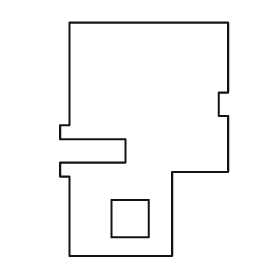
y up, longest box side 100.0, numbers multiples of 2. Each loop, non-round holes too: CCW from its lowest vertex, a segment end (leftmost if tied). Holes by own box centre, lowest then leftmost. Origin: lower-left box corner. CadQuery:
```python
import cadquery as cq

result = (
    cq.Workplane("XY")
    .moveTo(4.0, 0.0)
    .lineTo(48.0, 0.0)
    .lineTo(48.0, 36.0)
    .lineTo(72.0, 36.0)
    .lineTo(72.0, 60.0)
    .lineTo(68.0, 60.0)
    .lineTo(68.0, 70.0)
    .lineTo(72.0, 70.0)
    .lineTo(72.0, 100.0)
    .lineTo(4.0, 100.0)
    .lineTo(4.0, 56.0)
    .lineTo(0.0, 56.0)
    .lineTo(0.0, 50.0)
    .lineTo(28.0, 50.0)
    .lineTo(28.0, 40.0)
    .lineTo(0.0, 40.0)
    .lineTo(0.0, 34.0)
    .lineTo(4.0, 34.0)
    .close()
    .moveTo(22.0, 8.0)
    .lineTo(38.0, 8.0)
    .lineTo(38.0, 24.0)
    .lineTo(22.0, 24.0)
    .close()
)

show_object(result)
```